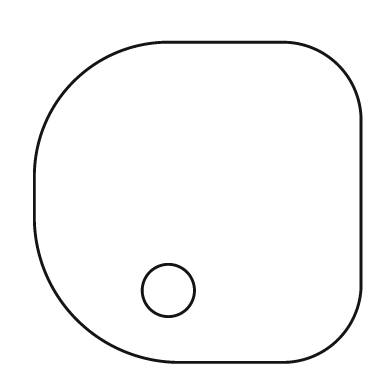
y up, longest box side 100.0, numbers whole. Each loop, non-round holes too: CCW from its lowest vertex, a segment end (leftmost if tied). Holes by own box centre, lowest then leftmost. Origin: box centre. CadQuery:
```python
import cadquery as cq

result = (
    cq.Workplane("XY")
    .moveTo(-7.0, -49.0)
    .lineTo(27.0, -49.0)
    .threePointArc((43.0, -42.0), (50.0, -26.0))
    .lineTo(50.0, 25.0)
    .threePointArc((43.0, 42.0), (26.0, 49.0))
    .lineTo(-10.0, 49.0)
    .threePointArc((-38.0, 37.0), (-50.0, 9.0))
    .lineTo(-50.0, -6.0)
    .threePointArc((-37.0, -36.0), (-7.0, -49.0))
    .close()
    .moveTo(-9.0, -27.0)
    .circle(8.0)
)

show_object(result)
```